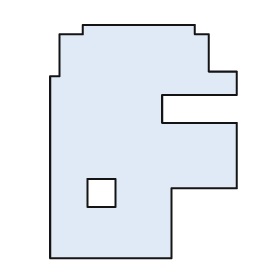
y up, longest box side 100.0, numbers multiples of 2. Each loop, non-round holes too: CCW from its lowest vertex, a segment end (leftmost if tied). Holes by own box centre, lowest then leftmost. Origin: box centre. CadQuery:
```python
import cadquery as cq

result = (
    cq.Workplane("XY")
    .moveTo(-40.0, -50.0)
    .lineTo(12.0, -50.0)
    .lineTo(12.0, -20.0)
    .lineTo(40.0, -20.0)
    .lineTo(40.0, 8.0)
    .lineTo(8.0, 8.0)
    .lineTo(8.0, 20.0)
    .lineTo(40.0, 20.0)
    .lineTo(40.0, 30.0)
    .lineTo(28.0, 30.0)
    .lineTo(28.0, 46.0)
    .lineTo(22.0, 46.0)
    .lineTo(22.0, 50.0)
    .lineTo(-26.0, 50.0)
    .lineTo(-26.0, 46.0)
    .lineTo(-36.0, 46.0)
    .lineTo(-36.0, 28.0)
    .lineTo(-40.0, 28.0)
    .close()
    .moveTo(-24.0, -28.0)
    .lineTo(-12.0, -28.0)
    .lineTo(-12.0, -16.0)
    .lineTo(-24.0, -16.0)
    .close()
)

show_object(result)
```